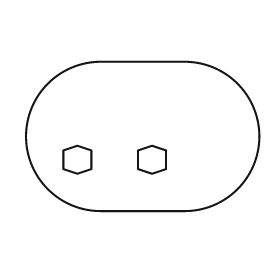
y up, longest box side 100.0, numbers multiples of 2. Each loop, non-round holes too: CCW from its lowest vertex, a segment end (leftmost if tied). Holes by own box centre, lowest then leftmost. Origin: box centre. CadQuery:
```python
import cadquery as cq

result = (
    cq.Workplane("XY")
    .moveTo(-18.0, -32.0)
    .lineTo(18.0, -32.0)
    .threePointArc((50.0, 0.0), (18.0, 32.0))
    .lineTo(-18.0, 32.0)
    .threePointArc((-50.0, 0.0), (-18.0, -32.0))
    .close()
    .moveTo(-28.0, -16.0)
    .lineTo(-22.0, -14.0)
    .lineTo(-22.0, -6.0)
    .lineTo(-28.0, -4.0)
    .lineTo(-34.0, -6.0)
    .lineTo(-34.0, -14.0)
    .close()
    .moveTo(4.0, -16.0)
    .lineTo(10.0, -14.0)
    .lineTo(10.0, -6.0)
    .lineTo(4.0, -4.0)
    .lineTo(-2.0, -6.0)
    .lineTo(-2.0, -14.0)
    .close()
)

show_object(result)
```